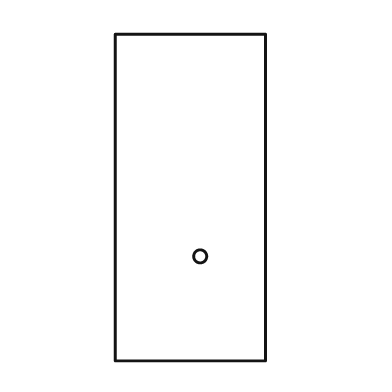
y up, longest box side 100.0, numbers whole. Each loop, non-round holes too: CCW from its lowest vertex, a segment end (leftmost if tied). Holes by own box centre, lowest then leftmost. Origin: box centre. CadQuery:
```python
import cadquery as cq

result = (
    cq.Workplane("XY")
    .moveTo(-23.0, -50.0)
    .lineTo(23.0, -50.0)
    .lineTo(23.0, 50.0)
    .lineTo(-23.0, 50.0)
    .close()
    .moveTo(3.0, -18.0)
    .circle(2.0)
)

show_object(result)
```